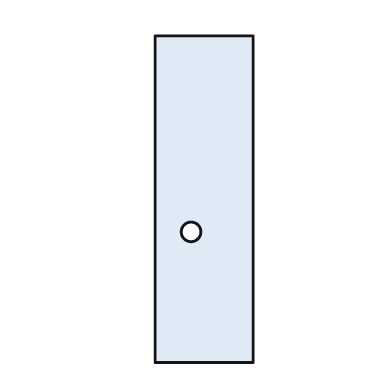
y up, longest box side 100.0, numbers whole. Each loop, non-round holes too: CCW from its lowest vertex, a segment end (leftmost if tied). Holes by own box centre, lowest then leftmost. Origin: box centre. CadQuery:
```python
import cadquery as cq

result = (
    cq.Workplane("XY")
    .moveTo(-15.0, -50.0)
    .lineTo(15.0, -50.0)
    .lineTo(15.0, 50.0)
    .lineTo(-15.0, 50.0)
    .close()
    .moveTo(-4.0, -10.0)
    .circle(3.0)
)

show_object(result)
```